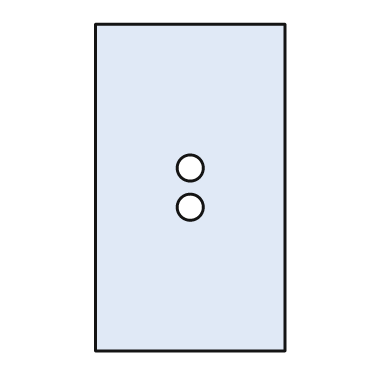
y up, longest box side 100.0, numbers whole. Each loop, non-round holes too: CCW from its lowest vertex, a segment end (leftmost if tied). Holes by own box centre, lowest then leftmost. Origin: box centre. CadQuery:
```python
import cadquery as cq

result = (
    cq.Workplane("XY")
    .moveTo(-29.0, -50.0)
    .lineTo(29.0, -50.0)
    .lineTo(29.0, 50.0)
    .lineTo(-29.0, 50.0)
    .close()
    .moveTo(0.0, -6.0)
    .circle(4.0)
    .moveTo(0.0, 6.0)
    .circle(4.0)
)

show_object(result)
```